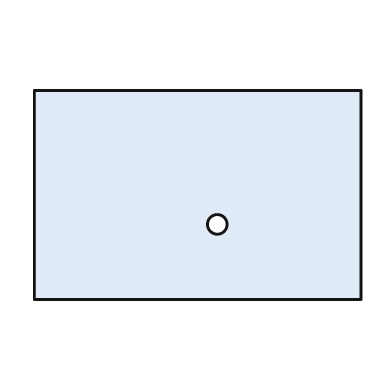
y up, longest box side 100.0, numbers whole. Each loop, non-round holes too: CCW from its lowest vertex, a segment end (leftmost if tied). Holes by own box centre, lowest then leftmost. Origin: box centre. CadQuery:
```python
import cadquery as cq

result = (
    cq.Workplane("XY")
    .moveTo(-50.0, -32.0)
    .lineTo(50.0, -32.0)
    .lineTo(50.0, 32.0)
    .lineTo(-50.0, 32.0)
    .close()
    .moveTo(6.0, -9.0)
    .circle(3.0)
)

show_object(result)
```